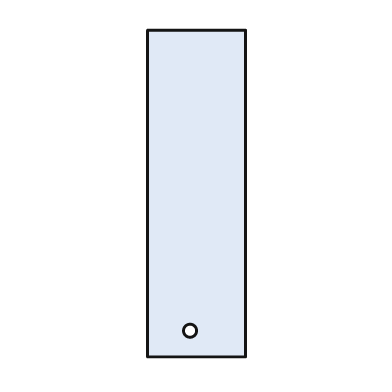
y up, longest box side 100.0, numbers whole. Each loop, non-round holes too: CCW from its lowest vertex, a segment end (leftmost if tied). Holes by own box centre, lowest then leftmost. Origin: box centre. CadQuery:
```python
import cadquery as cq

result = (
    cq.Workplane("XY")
    .moveTo(-15.0, -50.0)
    .lineTo(15.0, -50.0)
    .lineTo(15.0, 50.0)
    .lineTo(-15.0, 50.0)
    .close()
    .moveTo(-2.0, -42.0)
    .circle(2.0)
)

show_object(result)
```